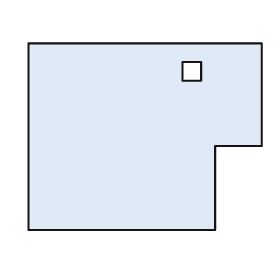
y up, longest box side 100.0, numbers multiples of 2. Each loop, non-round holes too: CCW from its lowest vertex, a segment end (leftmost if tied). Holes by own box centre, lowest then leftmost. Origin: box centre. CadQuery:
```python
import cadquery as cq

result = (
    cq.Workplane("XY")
    .moveTo(-50.0, -40.0)
    .lineTo(30.0, -40.0)
    .lineTo(30.0, -4.0)
    .lineTo(50.0, -4.0)
    .lineTo(50.0, 40.0)
    .lineTo(-50.0, 40.0)
    .close()
    .moveTo(16.0, 24.0)
    .lineTo(24.0, 24.0)
    .lineTo(24.0, 32.0)
    .lineTo(16.0, 32.0)
    .close()
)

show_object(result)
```